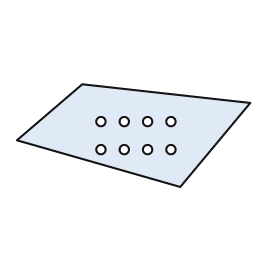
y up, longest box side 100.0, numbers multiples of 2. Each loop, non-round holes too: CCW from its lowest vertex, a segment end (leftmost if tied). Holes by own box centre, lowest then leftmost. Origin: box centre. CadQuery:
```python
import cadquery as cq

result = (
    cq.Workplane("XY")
    .moveTo(20.0, -22.0)
    .lineTo(50.0, 14.0)
    .lineTo(-22.0, 22.0)
    .lineTo(-50.0, -2.0)
    .close()
    .moveTo(-14.0, -6.0)
    .circle(2.0)
    .moveTo(-4.0, -6.0)
    .circle(2.0)
    .moveTo(6.0, -6.0)
    .circle(2.0)
    .moveTo(16.0, -6.0)
    .circle(2.0)
    .moveTo(-14.0, 6.0)
    .circle(2.0)
    .moveTo(-4.0, 6.0)
    .circle(2.0)
    .moveTo(6.0, 6.0)
    .circle(2.0)
    .moveTo(16.0, 6.0)
    .circle(2.0)
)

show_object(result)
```